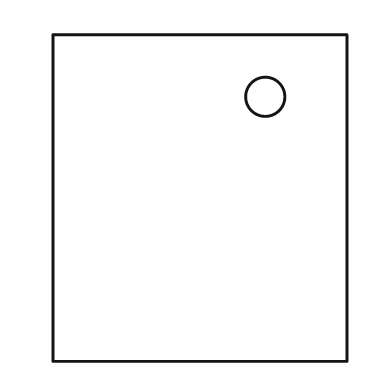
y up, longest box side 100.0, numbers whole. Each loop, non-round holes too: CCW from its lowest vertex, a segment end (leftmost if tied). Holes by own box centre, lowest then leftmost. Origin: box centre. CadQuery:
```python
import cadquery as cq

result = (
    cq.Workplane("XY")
    .moveTo(-45.0, -50.0)
    .lineTo(45.0, -50.0)
    .lineTo(45.0, 50.0)
    .lineTo(-45.0, 50.0)
    .close()
    .moveTo(20.0, 31.0)
    .circle(6.0)
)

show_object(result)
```